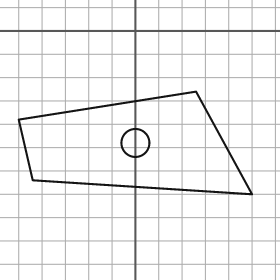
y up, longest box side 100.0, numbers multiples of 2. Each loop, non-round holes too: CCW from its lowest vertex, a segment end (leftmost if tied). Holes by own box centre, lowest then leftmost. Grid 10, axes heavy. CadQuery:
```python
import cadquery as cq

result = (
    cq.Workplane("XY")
    .moveTo(50.0, -70.0)
    .lineTo(26.0, -26.0)
    .lineTo(-50.0, -38.0)
    .lineTo(-44.0, -64.0)
    .close()
    .moveTo(0.0, -48.0)
    .circle(6.0)
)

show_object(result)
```